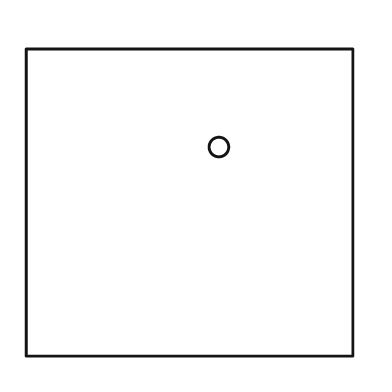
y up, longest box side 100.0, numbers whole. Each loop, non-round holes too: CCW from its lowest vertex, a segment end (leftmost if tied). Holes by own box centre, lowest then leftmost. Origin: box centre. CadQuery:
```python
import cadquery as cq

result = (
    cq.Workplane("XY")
    .moveTo(-50.0, -47.0)
    .lineTo(50.0, -47.0)
    .lineTo(50.0, 47.0)
    .lineTo(-50.0, 47.0)
    .close()
    .moveTo(9.0, 17.0)
    .circle(3.0)
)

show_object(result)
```